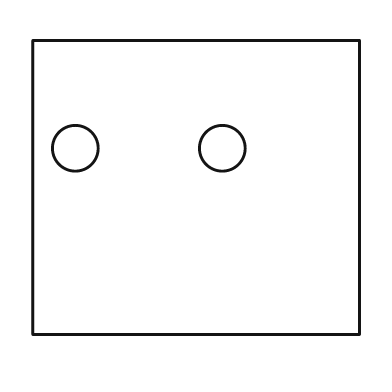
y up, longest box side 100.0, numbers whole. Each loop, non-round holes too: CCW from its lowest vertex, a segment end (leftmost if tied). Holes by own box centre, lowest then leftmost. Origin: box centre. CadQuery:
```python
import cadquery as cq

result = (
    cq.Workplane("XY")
    .moveTo(-50.0, -45.0)
    .lineTo(50.0, -45.0)
    .lineTo(50.0, 45.0)
    .lineTo(-50.0, 45.0)
    .close()
    .moveTo(-37.0, 12.0)
    .circle(7.0)
    .moveTo(8.0, 12.0)
    .circle(7.0)
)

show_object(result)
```